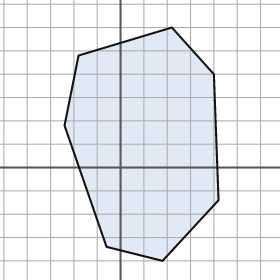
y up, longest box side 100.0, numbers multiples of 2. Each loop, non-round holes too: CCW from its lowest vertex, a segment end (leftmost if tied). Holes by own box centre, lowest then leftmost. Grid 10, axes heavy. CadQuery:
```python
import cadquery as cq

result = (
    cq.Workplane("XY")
    .moveTo(18.0, -40.0)
    .lineTo(42.0, -14.0)
    .lineTo(40.0, 40.0)
    .lineTo(22.0, 60.0)
    .lineTo(-18.0, 48.0)
    .lineTo(-24.0, 18.0)
    .lineTo(-6.0, -34.0)
    .close()
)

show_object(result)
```